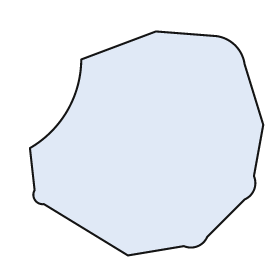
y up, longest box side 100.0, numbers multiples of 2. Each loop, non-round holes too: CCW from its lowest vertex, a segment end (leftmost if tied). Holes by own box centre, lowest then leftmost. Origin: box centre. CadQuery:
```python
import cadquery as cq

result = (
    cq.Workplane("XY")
    .moveTo(-8.0, -48.0)
    .lineTo(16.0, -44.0)
    .threePointArc((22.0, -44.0), (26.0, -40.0))
    .lineTo(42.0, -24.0)
    .threePointArc((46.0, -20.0), (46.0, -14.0))
    .lineTo(50.0, 8.0)
    .lineTo(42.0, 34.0)
    .threePointArc((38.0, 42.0), (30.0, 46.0))
    .lineTo(4.0, 48.0)
    .lineTo(-28.0, 36.0)
    .threePointArc((-34.0, 14.0), (-50.0, -2.0))
    .lineTo(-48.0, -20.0)
    .threePointArc((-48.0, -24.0), (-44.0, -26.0))
    .close()
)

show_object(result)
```